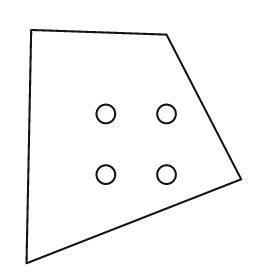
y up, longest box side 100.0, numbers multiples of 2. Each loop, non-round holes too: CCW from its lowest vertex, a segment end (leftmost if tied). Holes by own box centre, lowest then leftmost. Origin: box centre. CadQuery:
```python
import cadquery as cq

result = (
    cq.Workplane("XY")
    .moveTo(-46.0, -50.0)
    .lineTo(46.0, -14.0)
    .lineTo(14.0, 48.0)
    .lineTo(-44.0, 50.0)
    .close()
    .moveTo(-12.0, -12.0)
    .circle(4.0)
    .moveTo(14.0, -12.0)
    .circle(4.0)
    .moveTo(-12.0, 14.0)
    .circle(4.0)
    .moveTo(14.0, 14.0)
    .circle(4.0)
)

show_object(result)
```